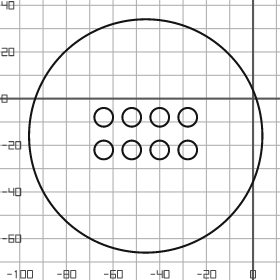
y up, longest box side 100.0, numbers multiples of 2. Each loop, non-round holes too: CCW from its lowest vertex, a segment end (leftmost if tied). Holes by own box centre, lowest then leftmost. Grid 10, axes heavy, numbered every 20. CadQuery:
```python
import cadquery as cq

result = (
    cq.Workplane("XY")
    .moveTo(-46.0, -16.0)
    .circle(50.0)
    .moveTo(-64.0, -22.0)
    .circle(4.0)
    .moveTo(-52.0, -22.0)
    .circle(4.0)
    .moveTo(-40.0, -22.0)
    .circle(4.0)
    .moveTo(-28.0, -22.0)
    .circle(4.0)
    .moveTo(-64.0, -8.0)
    .circle(4.0)
    .moveTo(-52.0, -8.0)
    .circle(4.0)
    .moveTo(-40.0, -8.0)
    .circle(4.0)
    .moveTo(-28.0, -8.0)
    .circle(4.0)
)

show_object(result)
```